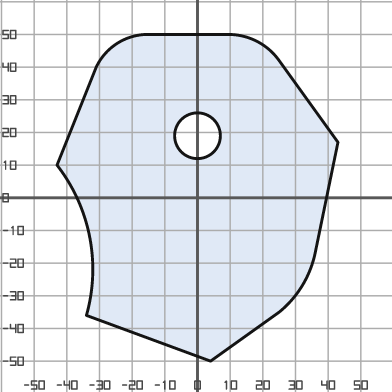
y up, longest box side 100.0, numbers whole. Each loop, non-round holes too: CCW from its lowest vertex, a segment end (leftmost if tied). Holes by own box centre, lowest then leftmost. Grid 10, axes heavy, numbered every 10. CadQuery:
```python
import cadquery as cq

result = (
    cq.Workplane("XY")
    .moveTo(4.0, -50.0)
    .lineTo(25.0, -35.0)
    .threePointArc((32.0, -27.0), (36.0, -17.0))
    .lineTo(43.0, 17.0)
    .lineTo(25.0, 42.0)
    .threePointArc((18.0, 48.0), (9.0, 50.0))
    .lineTo(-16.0, 50.0)
    .threePointArc((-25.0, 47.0), (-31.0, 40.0))
    .lineTo(-43.0, 10.0)
    .threePointArc((-33.0, -12.0), (-34.0, -36.0))
    .close()
    .moveTo(0.0, 19.0)
    .circle(7.0)
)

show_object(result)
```